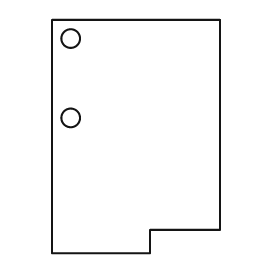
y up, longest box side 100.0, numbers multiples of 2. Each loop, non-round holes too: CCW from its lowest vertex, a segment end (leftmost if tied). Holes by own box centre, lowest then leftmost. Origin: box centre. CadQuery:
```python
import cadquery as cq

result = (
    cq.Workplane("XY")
    .moveTo(-36.0, -50.0)
    .lineTo(6.0, -50.0)
    .lineTo(6.0, -40.0)
    .lineTo(36.0, -40.0)
    .lineTo(36.0, 50.0)
    .lineTo(-36.0, 50.0)
    .close()
    .moveTo(-28.0, 8.0)
    .circle(4.0)
    .moveTo(-28.0, 42.0)
    .circle(4.0)
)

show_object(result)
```